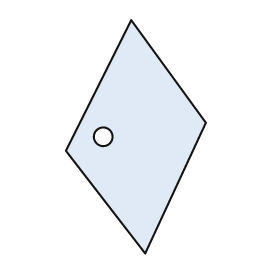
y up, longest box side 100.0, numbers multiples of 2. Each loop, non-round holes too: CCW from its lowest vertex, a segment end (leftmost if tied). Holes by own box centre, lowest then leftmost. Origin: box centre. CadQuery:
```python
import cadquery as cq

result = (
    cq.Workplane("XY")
    .moveTo(4.0, -50.0)
    .lineTo(30.0, 6.0)
    .lineTo(-2.0, 50.0)
    .lineTo(-30.0, -6.0)
    .close()
    .moveTo(-14.0, 0.0)
    .circle(4.0)
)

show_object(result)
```